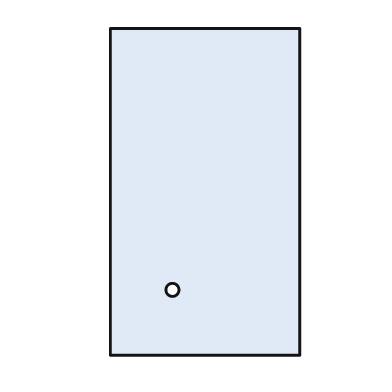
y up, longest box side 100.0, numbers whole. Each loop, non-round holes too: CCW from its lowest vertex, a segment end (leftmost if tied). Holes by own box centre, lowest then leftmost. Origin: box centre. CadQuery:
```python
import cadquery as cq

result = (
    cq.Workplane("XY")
    .moveTo(-29.0, -50.0)
    .lineTo(29.0, -50.0)
    .lineTo(29.0, 50.0)
    .lineTo(-29.0, 50.0)
    .close()
    .moveTo(-10.0, -30.0)
    .circle(2.0)
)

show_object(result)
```